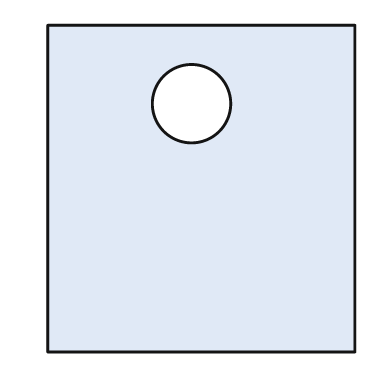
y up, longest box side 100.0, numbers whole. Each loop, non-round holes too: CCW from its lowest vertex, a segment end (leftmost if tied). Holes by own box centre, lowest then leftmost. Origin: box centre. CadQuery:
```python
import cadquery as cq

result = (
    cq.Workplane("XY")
    .moveTo(-47.0, -50.0)
    .lineTo(47.0, -50.0)
    .lineTo(47.0, 50.0)
    .lineTo(-47.0, 50.0)
    .close()
    .moveTo(-3.0, 26.0)
    .circle(12.0)
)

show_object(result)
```